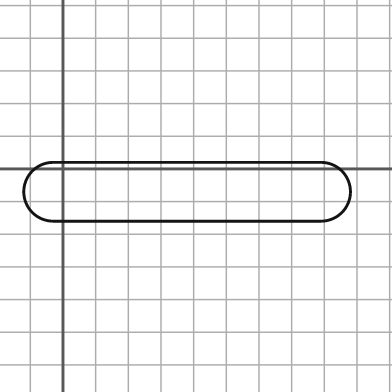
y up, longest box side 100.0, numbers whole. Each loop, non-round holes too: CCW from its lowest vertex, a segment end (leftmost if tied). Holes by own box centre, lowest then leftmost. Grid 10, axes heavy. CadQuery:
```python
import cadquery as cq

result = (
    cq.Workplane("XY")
    .moveTo(-3.0, -16.0)
    .lineTo(79.0, -16.0)
    .threePointArc((88.0, -7.0), (79.0, 2.0))
    .lineTo(-3.0, 2.0)
    .threePointArc((-12.0, -7.0), (-3.0, -16.0))
    .close()
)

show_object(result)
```